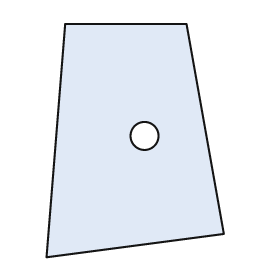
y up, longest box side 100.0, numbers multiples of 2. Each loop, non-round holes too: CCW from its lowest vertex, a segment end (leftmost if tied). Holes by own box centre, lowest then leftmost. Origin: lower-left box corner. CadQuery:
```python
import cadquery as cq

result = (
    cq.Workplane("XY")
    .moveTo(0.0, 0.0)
    .lineTo(76.0, 10.0)
    .lineTo(60.0, 100.0)
    .lineTo(8.0, 100.0)
    .close()
    .moveTo(42.0, 52.0)
    .circle(6.0)
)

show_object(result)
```